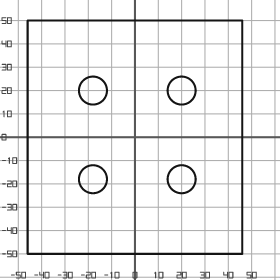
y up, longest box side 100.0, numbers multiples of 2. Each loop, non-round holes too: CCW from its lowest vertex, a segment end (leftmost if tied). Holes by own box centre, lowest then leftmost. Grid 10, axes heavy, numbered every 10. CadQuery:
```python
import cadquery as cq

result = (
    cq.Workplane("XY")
    .moveTo(-46.0, -50.0)
    .lineTo(46.0, -50.0)
    .lineTo(46.0, 50.0)
    .lineTo(-46.0, 50.0)
    .close()
    .moveTo(-18.0, -18.0)
    .circle(6.0)
    .moveTo(20.0, -18.0)
    .circle(6.0)
    .moveTo(-18.0, 20.0)
    .circle(6.0)
    .moveTo(20.0, 20.0)
    .circle(6.0)
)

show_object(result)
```